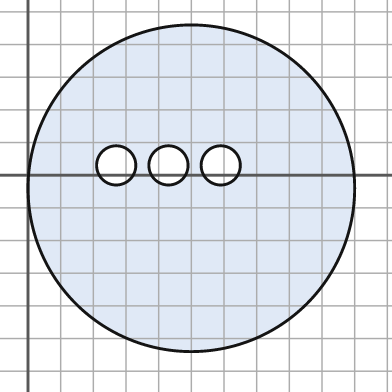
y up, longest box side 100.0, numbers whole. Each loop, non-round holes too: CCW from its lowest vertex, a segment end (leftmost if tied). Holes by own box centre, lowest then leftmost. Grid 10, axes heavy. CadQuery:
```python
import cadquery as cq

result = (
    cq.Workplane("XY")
    .moveTo(50.0, -4.0)
    .circle(50.0)
    .moveTo(27.0, 3.0)
    .circle(6.0)
    .moveTo(43.0, 3.0)
    .circle(6.0)
    .moveTo(59.0, 3.0)
    .circle(6.0)
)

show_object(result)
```